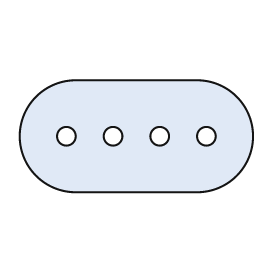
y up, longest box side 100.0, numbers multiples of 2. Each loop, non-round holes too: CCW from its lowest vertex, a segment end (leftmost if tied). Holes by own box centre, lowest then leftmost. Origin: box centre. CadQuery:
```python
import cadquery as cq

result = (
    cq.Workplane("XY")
    .moveTo(-26.0, -24.0)
    .lineTo(26.0, -24.0)
    .threePointArc((50.0, 0.0), (26.0, 24.0))
    .lineTo(-26.0, 24.0)
    .threePointArc((-50.0, 0.0), (-26.0, -24.0))
    .close()
    .moveTo(-30.0, 0.0)
    .circle(4.0)
    .moveTo(-10.0, 0.0)
    .circle(4.0)
    .moveTo(10.0, 0.0)
    .circle(4.0)
    .moveTo(30.0, 0.0)
    .circle(4.0)
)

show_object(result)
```